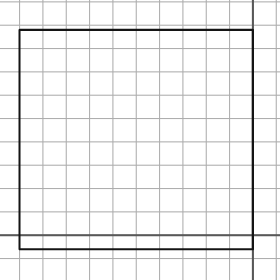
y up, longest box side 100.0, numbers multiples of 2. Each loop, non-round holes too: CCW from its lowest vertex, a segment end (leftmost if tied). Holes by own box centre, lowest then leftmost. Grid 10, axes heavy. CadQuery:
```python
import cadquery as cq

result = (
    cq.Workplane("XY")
    .moveTo(-100.0, -6.0)
    .lineTo(0.0, -6.0)
    .lineTo(0.0, 88.0)
    .lineTo(-100.0, 88.0)
    .close()
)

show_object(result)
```